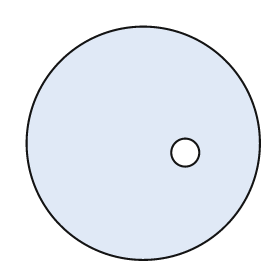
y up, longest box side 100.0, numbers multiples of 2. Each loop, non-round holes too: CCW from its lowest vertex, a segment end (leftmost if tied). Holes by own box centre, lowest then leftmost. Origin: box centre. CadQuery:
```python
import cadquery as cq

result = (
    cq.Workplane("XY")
    .moveTo(0.0, 0.0)
    .circle(50.0)
    .moveTo(18.0, -4.0)
    .circle(6.0)
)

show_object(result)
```